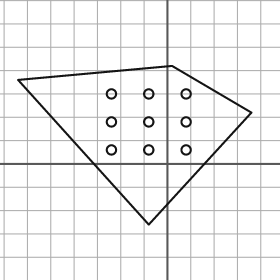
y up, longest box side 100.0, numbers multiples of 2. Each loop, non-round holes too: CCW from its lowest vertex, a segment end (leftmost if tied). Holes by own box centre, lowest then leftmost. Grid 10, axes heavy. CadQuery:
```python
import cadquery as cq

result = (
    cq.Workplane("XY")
    .moveTo(-8.0, -26.0)
    .lineTo(36.0, 22.0)
    .lineTo(2.0, 42.0)
    .lineTo(-64.0, 36.0)
    .close()
    .moveTo(-24.0, 6.0)
    .circle(2.0)
    .moveTo(-8.0, 6.0)
    .circle(2.0)
    .moveTo(8.0, 6.0)
    .circle(2.0)
    .moveTo(-24.0, 18.0)
    .circle(2.0)
    .moveTo(-8.0, 18.0)
    .circle(2.0)
    .moveTo(8.0, 18.0)
    .circle(2.0)
    .moveTo(-24.0, 30.0)
    .circle(2.0)
    .moveTo(-8.0, 30.0)
    .circle(2.0)
    .moveTo(8.0, 30.0)
    .circle(2.0)
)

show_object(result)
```